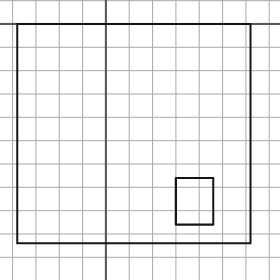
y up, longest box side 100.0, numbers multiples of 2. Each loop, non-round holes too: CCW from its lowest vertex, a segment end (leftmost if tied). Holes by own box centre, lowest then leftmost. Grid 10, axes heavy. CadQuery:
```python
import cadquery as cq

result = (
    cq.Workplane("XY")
    .moveTo(-38.0, -94.0)
    .lineTo(62.0, -94.0)
    .lineTo(62.0, 0.0)
    .lineTo(-38.0, 0.0)
    .close()
    .moveTo(30.0, -86.0)
    .lineTo(46.0, -86.0)
    .lineTo(46.0, -66.0)
    .lineTo(30.0, -66.0)
    .close()
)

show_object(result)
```